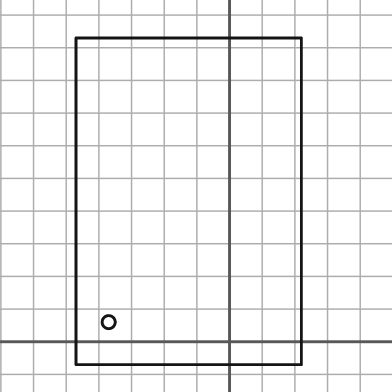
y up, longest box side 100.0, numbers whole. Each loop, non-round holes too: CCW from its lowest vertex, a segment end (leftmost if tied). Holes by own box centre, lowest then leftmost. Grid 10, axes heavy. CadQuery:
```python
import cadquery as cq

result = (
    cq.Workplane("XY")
    .moveTo(-47.0, -7.0)
    .lineTo(22.0, -7.0)
    .lineTo(22.0, 93.0)
    .lineTo(-47.0, 93.0)
    .close()
    .moveTo(-37.0, 6.0)
    .circle(2.0)
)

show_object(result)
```